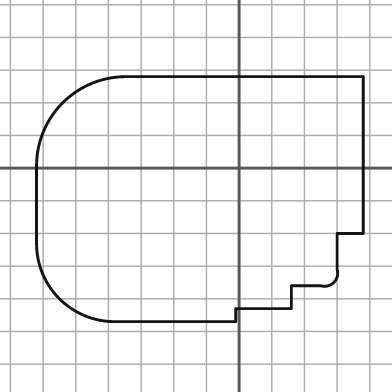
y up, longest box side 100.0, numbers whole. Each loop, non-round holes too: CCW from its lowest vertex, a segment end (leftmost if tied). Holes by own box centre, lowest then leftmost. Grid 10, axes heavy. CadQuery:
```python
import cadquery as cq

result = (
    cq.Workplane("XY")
    .moveTo(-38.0, -47.0)
    .lineTo(-1.0, -47.0)
    .lineTo(-1.0, -43.0)
    .lineTo(16.0, -43.0)
    .lineTo(16.0, -36.0)
    .lineTo(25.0, -36.0)
    .threePointArc((29.0, -35.0), (30.0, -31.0))
    .lineTo(30.0, -20.0)
    .lineTo(38.0, -20.0)
    .lineTo(38.0, 28.0)
    .lineTo(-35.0, 28.0)
    .threePointArc((-54.0, 20.0), (-62.0, 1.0))
    .lineTo(-62.0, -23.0)
    .threePointArc((-55.0, -40.0), (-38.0, -47.0))
    .close()
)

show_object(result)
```